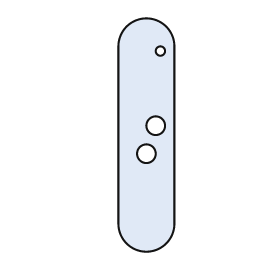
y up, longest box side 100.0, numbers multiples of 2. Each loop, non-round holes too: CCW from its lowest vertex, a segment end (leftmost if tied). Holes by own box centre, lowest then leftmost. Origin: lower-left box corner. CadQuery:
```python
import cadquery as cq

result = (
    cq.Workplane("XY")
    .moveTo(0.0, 12.0)
    .threePointArc((12.0, 0.0), (24.0, 12.0))
    .lineTo(24.0, 88.0)
    .threePointArc((12.0, 100.0), (0.0, 88.0))
    .close()
    .moveTo(12.0, 42.0)
    .circle(4.0)
    .moveTo(16.0, 54.0)
    .circle(4.0)
    .moveTo(18.0, 86.0)
    .circle(2.0)
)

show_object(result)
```